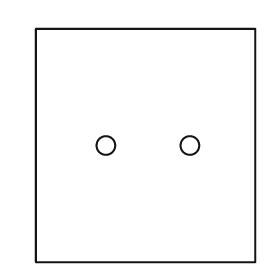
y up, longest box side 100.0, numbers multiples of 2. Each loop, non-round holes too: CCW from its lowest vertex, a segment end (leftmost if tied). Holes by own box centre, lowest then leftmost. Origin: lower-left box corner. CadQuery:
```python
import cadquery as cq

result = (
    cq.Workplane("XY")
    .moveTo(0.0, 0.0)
    .lineTo(94.0, 0.0)
    .lineTo(94.0, 100.0)
    .lineTo(0.0, 100.0)
    .close()
    .moveTo(30.0, 50.0)
    .circle(4.0)
    .moveTo(66.0, 50.0)
    .circle(4.0)
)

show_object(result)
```